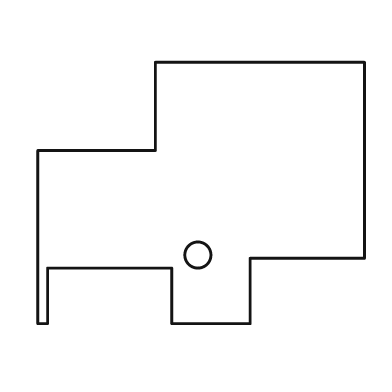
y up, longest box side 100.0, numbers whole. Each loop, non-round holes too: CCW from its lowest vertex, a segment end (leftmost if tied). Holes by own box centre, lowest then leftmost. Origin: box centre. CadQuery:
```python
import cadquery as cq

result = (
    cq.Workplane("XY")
    .moveTo(-50.0, -40.0)
    .lineTo(-47.0, -40.0)
    .lineTo(-47.0, -23.0)
    .lineTo(-9.0, -23.0)
    .lineTo(-9.0, -40.0)
    .lineTo(15.0, -40.0)
    .lineTo(15.0, -20.0)
    .lineTo(50.0, -20.0)
    .lineTo(50.0, 40.0)
    .lineTo(-14.0, 40.0)
    .lineTo(-14.0, 13.0)
    .lineTo(-50.0, 13.0)
    .close()
    .moveTo(-1.0, -19.0)
    .circle(4.0)
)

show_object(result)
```